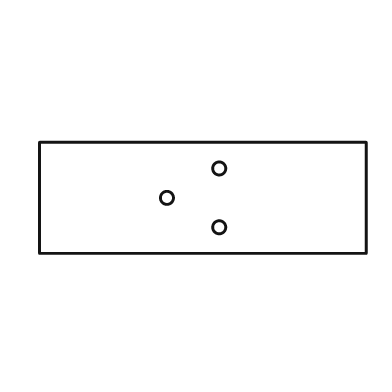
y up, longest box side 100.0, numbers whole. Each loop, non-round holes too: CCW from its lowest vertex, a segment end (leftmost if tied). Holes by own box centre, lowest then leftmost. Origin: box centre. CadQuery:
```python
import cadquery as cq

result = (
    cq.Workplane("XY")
    .moveTo(-50.0, -17.0)
    .lineTo(50.0, -17.0)
    .lineTo(50.0, 17.0)
    .lineTo(-50.0, 17.0)
    .close()
    .moveTo(5.0, -9.0)
    .circle(2.0)
    .moveTo(-11.0, 0.0)
    .circle(2.0)
    .moveTo(5.0, 9.0)
    .circle(2.0)
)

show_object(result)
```